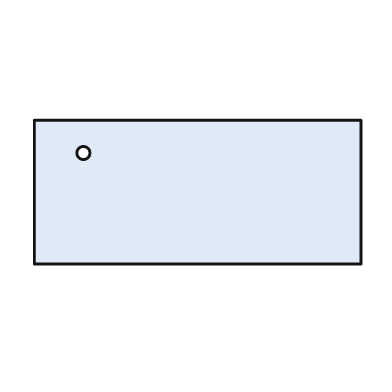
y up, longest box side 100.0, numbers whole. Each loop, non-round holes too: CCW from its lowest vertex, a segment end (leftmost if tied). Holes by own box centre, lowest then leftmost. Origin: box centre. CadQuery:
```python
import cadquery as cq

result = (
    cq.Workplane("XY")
    .moveTo(-50.0, -22.0)
    .lineTo(50.0, -22.0)
    .lineTo(50.0, 22.0)
    .lineTo(-50.0, 22.0)
    .close()
    .moveTo(-35.0, 12.0)
    .circle(2.0)
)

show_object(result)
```